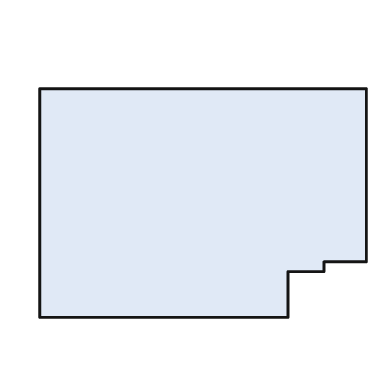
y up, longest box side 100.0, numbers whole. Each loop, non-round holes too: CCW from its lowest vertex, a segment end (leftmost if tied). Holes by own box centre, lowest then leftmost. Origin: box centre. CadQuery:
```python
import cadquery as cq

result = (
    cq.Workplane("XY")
    .moveTo(-50.0, -35.0)
    .lineTo(26.0, -35.0)
    .lineTo(26.0, -21.0)
    .lineTo(37.0, -21.0)
    .lineTo(37.0, -18.0)
    .lineTo(50.0, -18.0)
    .lineTo(50.0, 35.0)
    .lineTo(-50.0, 35.0)
    .close()
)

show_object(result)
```